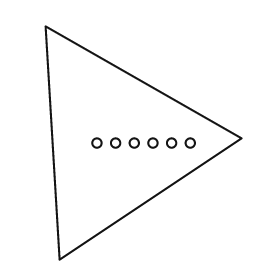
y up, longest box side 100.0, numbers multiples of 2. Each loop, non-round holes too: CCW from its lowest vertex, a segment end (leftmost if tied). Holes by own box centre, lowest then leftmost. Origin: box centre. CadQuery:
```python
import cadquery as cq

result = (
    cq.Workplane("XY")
    .moveTo(-36.0, -50.0)
    .lineTo(42.0, 2.0)
    .lineTo(-42.0, 50.0)
    .close()
    .moveTo(-20.0, 0.0)
    .circle(2.0)
    .moveTo(-12.0, 0.0)
    .circle(2.0)
    .moveTo(-4.0, 0.0)
    .circle(2.0)
    .moveTo(4.0, 0.0)
    .circle(2.0)
    .moveTo(12.0, 0.0)
    .circle(2.0)
    .moveTo(20.0, 0.0)
    .circle(2.0)
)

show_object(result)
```